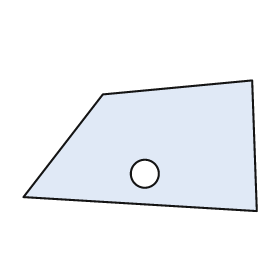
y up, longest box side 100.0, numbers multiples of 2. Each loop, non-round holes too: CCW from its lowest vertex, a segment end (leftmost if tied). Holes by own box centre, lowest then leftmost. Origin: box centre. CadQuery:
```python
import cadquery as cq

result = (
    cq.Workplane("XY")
    .moveTo(50.0, -28.0)
    .lineTo(48.0, 28.0)
    .lineTo(-16.0, 22.0)
    .lineTo(-50.0, -22.0)
    .close()
    .moveTo(2.0, -12.0)
    .circle(6.0)
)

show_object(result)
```